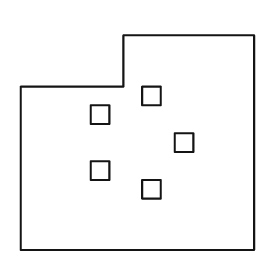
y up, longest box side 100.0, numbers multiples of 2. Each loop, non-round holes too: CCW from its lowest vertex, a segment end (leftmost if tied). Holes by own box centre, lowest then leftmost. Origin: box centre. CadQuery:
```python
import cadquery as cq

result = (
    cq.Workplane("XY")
    .moveTo(-50.0, -46.0)
    .lineTo(50.0, -46.0)
    .lineTo(50.0, 46.0)
    .lineTo(-6.0, 46.0)
    .lineTo(-6.0, 24.0)
    .lineTo(-50.0, 24.0)
    .close()
    .moveTo(2.0, -24.0)
    .lineTo(10.0, -24.0)
    .lineTo(10.0, -16.0)
    .lineTo(2.0, -16.0)
    .close()
    .moveTo(-20.0, -16.0)
    .lineTo(-12.0, -16.0)
    .lineTo(-12.0, -8.0)
    .lineTo(-20.0, -8.0)
    .close()
    .moveTo(16.0, -4.0)
    .lineTo(24.0, -4.0)
    .lineTo(24.0, 4.0)
    .lineTo(16.0, 4.0)
    .close()
    .moveTo(-20.0, 8.0)
    .lineTo(-12.0, 8.0)
    .lineTo(-12.0, 16.0)
    .lineTo(-20.0, 16.0)
    .close()
    .moveTo(2.0, 16.0)
    .lineTo(10.0, 16.0)
    .lineTo(10.0, 24.0)
    .lineTo(2.0, 24.0)
    .close()
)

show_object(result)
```